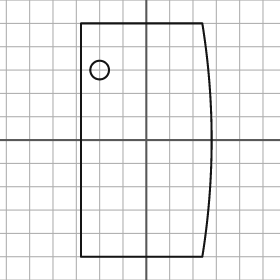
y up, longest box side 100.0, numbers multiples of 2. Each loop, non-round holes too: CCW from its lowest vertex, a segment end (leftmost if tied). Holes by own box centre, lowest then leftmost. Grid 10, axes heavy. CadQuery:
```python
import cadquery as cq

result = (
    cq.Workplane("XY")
    .moveTo(-28.0, -50.0)
    .lineTo(24.0, -50.0)
    .threePointArc((28.0, 0.0), (24.0, 50.0))
    .lineTo(-28.0, 50.0)
    .close()
    .moveTo(-20.0, 30.0)
    .circle(4.0)
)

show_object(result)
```